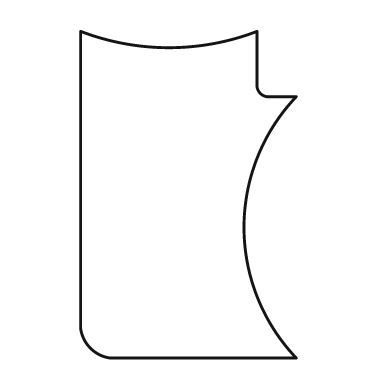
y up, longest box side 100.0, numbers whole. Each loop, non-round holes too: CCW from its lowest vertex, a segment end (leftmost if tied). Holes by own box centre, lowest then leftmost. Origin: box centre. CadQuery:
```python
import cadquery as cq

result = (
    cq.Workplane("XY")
    .moveTo(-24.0, -50.0)
    .lineTo(33.0, -50.0)
    .threePointArc((17.0, -10.0), (33.0, 30.0))
    .lineTo(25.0, 30.0)
    .threePointArc((22.0, 31.0), (21.0, 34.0))
    .lineTo(21.0, 50.0)
    .threePointArc((-6.0, 45.0), (-33.0, 50.0))
    .lineTo(-33.0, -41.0)
    .threePointArc((-30.0, -47.0), (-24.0, -50.0))
    .close()
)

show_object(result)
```